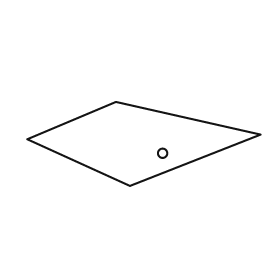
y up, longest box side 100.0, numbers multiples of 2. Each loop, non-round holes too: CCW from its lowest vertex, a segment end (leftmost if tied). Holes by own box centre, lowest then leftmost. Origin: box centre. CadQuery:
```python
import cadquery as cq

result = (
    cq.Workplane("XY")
    .moveTo(-6.0, -18.0)
    .lineTo(50.0, 4.0)
    .lineTo(-12.0, 18.0)
    .lineTo(-50.0, 2.0)
    .close()
    .moveTo(8.0, -4.0)
    .circle(2.0)
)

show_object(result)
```